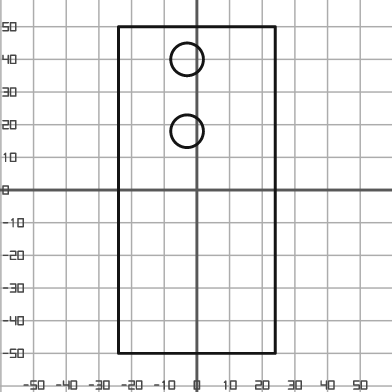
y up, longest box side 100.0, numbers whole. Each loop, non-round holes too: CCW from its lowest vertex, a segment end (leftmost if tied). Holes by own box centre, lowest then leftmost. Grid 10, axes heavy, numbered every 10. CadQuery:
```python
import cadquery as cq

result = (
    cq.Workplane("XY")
    .moveTo(-24.0, -50.0)
    .lineTo(24.0, -50.0)
    .lineTo(24.0, 50.0)
    .lineTo(-24.0, 50.0)
    .close()
    .moveTo(-3.0, 18.0)
    .circle(5.0)
    .moveTo(-3.0, 40.0)
    .circle(5.0)
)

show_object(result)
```